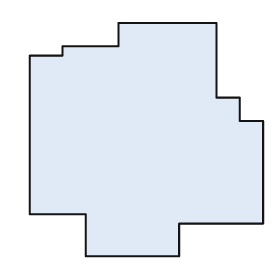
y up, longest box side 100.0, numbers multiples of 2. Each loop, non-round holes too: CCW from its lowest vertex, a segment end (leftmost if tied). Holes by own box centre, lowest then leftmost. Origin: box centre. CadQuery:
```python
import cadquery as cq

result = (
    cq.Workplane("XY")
    .moveTo(-26.0, -50.0)
    .lineTo(14.0, -50.0)
    .lineTo(14.0, -36.0)
    .lineTo(50.0, -36.0)
    .lineTo(50.0, 8.0)
    .lineTo(40.0, 8.0)
    .lineTo(40.0, 18.0)
    .lineTo(30.0, 18.0)
    .lineTo(30.0, 50.0)
    .lineTo(-12.0, 50.0)
    .lineTo(-12.0, 40.0)
    .lineTo(-36.0, 40.0)
    .lineTo(-36.0, 36.0)
    .lineTo(-50.0, 36.0)
    .lineTo(-50.0, -32.0)
    .lineTo(-26.0, -32.0)
    .close()
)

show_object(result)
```